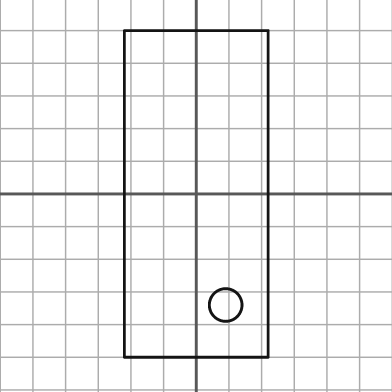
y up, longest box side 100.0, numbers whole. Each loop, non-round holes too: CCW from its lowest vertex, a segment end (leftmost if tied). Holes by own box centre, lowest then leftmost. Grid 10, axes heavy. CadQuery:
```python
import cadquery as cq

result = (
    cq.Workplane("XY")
    .moveTo(-22.0, -50.0)
    .lineTo(22.0, -50.0)
    .lineTo(22.0, 50.0)
    .lineTo(-22.0, 50.0)
    .close()
    .moveTo(9.0, -34.0)
    .circle(5.0)
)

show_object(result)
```